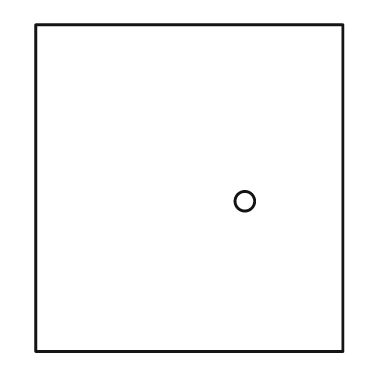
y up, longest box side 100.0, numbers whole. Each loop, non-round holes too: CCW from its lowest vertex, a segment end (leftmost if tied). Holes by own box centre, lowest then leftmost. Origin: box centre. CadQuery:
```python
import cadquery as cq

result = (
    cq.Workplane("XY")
    .moveTo(-47.0, -50.0)
    .lineTo(47.0, -50.0)
    .lineTo(47.0, 50.0)
    .lineTo(-47.0, 50.0)
    .close()
    .moveTo(17.0, -4.0)
    .circle(3.0)
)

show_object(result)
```